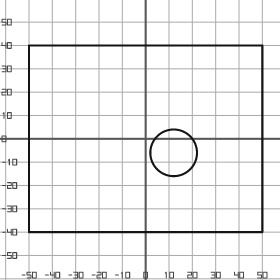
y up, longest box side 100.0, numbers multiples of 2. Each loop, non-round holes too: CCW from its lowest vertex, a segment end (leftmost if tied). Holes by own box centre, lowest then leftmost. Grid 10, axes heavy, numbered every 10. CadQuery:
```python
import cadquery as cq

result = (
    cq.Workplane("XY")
    .moveTo(-50.0, -40.0)
    .lineTo(50.0, -40.0)
    .lineTo(50.0, 40.0)
    .lineTo(-50.0, 40.0)
    .close()
    .moveTo(12.0, -6.0)
    .circle(10.0)
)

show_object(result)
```